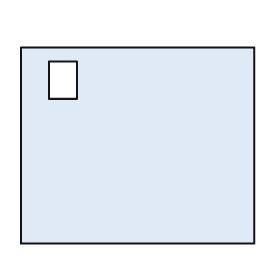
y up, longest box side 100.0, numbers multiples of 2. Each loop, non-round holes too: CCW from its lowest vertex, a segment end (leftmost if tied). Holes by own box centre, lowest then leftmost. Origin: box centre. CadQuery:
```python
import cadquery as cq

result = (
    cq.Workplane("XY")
    .moveTo(-50.0, -42.0)
    .lineTo(50.0, -42.0)
    .lineTo(50.0, 42.0)
    .lineTo(-50.0, 42.0)
    .close()
    .moveTo(-38.0, 20.0)
    .lineTo(-26.0, 20.0)
    .lineTo(-26.0, 36.0)
    .lineTo(-38.0, 36.0)
    .close()
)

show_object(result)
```